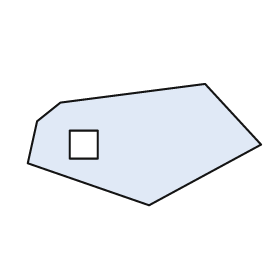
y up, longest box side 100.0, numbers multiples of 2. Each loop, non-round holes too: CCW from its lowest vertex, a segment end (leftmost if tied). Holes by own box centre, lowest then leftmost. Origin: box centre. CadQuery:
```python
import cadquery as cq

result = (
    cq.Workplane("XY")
    .moveTo(2.0, -26.0)
    .lineTo(50.0, 0.0)
    .lineTo(26.0, 26.0)
    .lineTo(-36.0, 18.0)
    .lineTo(-46.0, 10.0)
    .lineTo(-50.0, -8.0)
    .close()
    .moveTo(-32.0, -6.0)
    .lineTo(-20.0, -6.0)
    .lineTo(-20.0, 6.0)
    .lineTo(-32.0, 6.0)
    .close()
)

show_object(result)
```